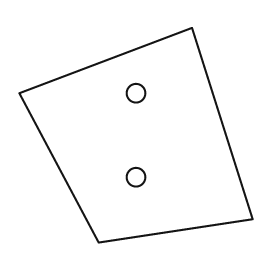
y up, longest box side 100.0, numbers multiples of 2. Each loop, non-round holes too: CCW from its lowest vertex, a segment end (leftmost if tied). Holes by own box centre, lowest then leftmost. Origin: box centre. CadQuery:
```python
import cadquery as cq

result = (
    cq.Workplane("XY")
    .moveTo(-16.0, -46.0)
    .lineTo(50.0, -36.0)
    .lineTo(24.0, 46.0)
    .lineTo(-50.0, 18.0)
    .close()
    .moveTo(0.0, -18.0)
    .circle(4.0)
    .moveTo(0.0, 18.0)
    .circle(4.0)
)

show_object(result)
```